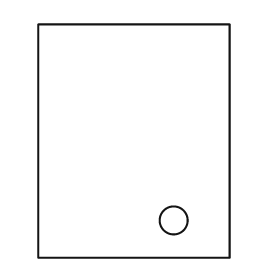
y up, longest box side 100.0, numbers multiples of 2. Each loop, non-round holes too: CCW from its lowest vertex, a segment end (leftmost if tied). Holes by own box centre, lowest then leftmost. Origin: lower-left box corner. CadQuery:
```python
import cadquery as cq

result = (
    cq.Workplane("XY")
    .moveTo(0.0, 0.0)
    .lineTo(82.0, 0.0)
    .lineTo(82.0, 100.0)
    .lineTo(0.0, 100.0)
    .close()
    .moveTo(58.0, 16.0)
    .circle(6.0)
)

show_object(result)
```